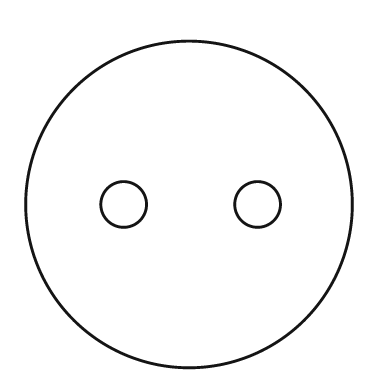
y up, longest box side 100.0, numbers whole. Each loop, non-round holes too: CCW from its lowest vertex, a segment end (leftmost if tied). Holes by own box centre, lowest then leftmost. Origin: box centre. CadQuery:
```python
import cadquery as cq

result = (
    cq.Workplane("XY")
    .moveTo(0.0, 0.0)
    .circle(50.0)
    .moveTo(-20.0, 0.0)
    .circle(7.0)
    .moveTo(21.0, 0.0)
    .circle(7.0)
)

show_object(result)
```